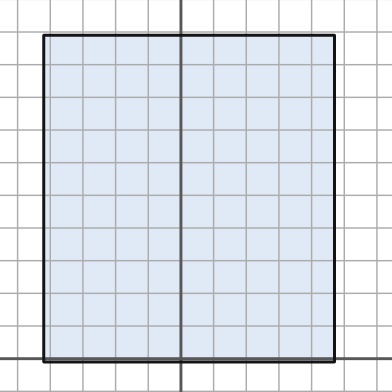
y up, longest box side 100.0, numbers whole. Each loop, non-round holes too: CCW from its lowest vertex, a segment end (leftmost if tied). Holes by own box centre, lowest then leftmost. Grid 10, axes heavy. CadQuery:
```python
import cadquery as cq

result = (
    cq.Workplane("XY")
    .moveTo(-42.0, -1.0)
    .lineTo(47.0, -1.0)
    .lineTo(47.0, 99.0)
    .lineTo(-42.0, 99.0)
    .close()
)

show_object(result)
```